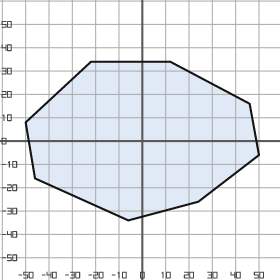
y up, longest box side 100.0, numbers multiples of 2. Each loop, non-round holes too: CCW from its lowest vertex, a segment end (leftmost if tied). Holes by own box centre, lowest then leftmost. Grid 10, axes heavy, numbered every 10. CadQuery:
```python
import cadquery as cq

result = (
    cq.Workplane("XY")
    .moveTo(-6.0, -34.0)
    .lineTo(24.0, -26.0)
    .lineTo(50.0, -6.0)
    .lineTo(46.0, 16.0)
    .lineTo(12.0, 34.0)
    .lineTo(-22.0, 34.0)
    .lineTo(-50.0, 8.0)
    .lineTo(-46.0, -16.0)
    .close()
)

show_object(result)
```